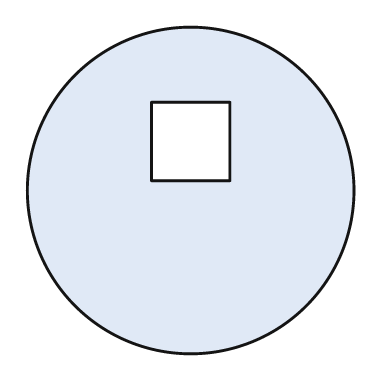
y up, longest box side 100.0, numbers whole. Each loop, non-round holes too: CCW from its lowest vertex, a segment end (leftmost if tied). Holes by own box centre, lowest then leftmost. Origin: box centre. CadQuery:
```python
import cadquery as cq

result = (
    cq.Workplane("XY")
    .moveTo(0.0, 0.0)
    .circle(50.0)
    .moveTo(-12.0, 3.0)
    .lineTo(12.0, 3.0)
    .lineTo(12.0, 27.0)
    .lineTo(-12.0, 27.0)
    .close()
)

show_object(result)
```